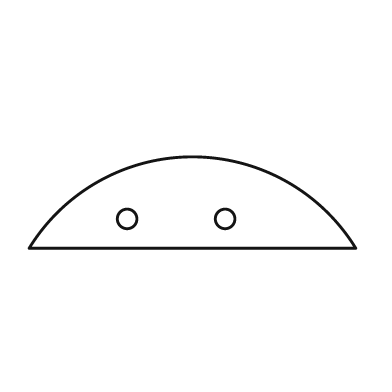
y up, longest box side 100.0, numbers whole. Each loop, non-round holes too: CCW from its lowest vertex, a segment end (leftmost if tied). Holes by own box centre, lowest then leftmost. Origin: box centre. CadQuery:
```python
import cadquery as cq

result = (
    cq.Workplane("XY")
    .moveTo(-50.0, -14.0)
    .lineTo(50.0, -14.0)
    .threePointArc((0.0, 14.0), (-50.0, -14.0))
    .close()
    .moveTo(-20.0, -5.0)
    .circle(3.0)
    .moveTo(10.0, -5.0)
    .circle(3.0)
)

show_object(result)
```